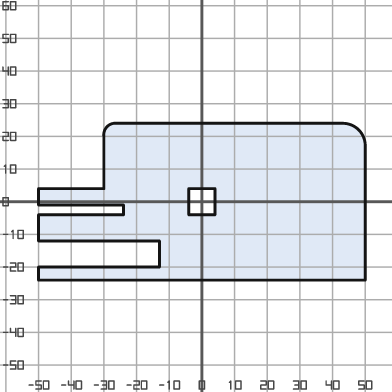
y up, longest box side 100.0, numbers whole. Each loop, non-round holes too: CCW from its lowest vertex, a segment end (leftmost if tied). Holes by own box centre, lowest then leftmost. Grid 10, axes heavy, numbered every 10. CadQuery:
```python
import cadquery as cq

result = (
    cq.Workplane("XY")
    .moveTo(-50.0, -24.0)
    .lineTo(50.0, -24.0)
    .lineTo(50.0, 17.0)
    .threePointArc((48.0, 22.0), (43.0, 24.0))
    .lineTo(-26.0, 24.0)
    .threePointArc((-29.0, 23.0), (-30.0, 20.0))
    .lineTo(-30.0, 4.0)
    .lineTo(-50.0, 4.0)
    .lineTo(-50.0, -1.0)
    .lineTo(-24.0, -1.0)
    .lineTo(-24.0, -4.0)
    .lineTo(-50.0, -4.0)
    .lineTo(-50.0, -12.0)
    .lineTo(-13.0, -12.0)
    .lineTo(-13.0, -20.0)
    .lineTo(-50.0, -20.0)
    .close()
    .moveTo(-4.0, -4.0)
    .lineTo(4.0, -4.0)
    .lineTo(4.0, 4.0)
    .lineTo(-4.0, 4.0)
    .close()
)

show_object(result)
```